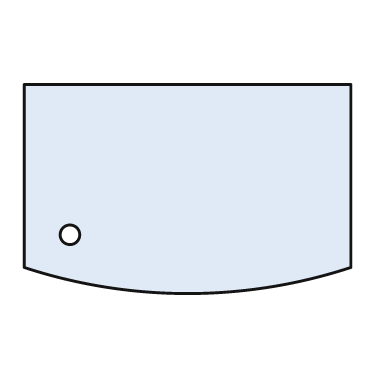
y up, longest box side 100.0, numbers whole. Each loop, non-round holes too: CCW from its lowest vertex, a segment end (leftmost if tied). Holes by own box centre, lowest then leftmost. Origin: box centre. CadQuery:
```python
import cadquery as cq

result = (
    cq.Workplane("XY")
    .moveTo(-50.0, -24.0)
    .threePointArc((0.0, -32.0), (50.0, -24.0))
    .lineTo(50.0, 32.0)
    .lineTo(-50.0, 32.0)
    .close()
    .moveTo(-36.0, -14.0)
    .circle(3.0)
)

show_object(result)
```